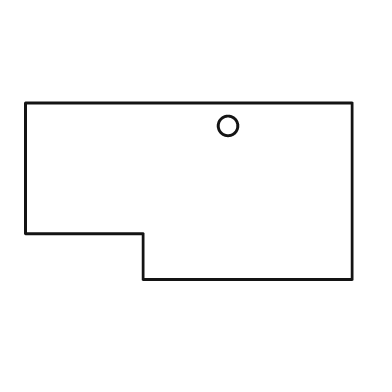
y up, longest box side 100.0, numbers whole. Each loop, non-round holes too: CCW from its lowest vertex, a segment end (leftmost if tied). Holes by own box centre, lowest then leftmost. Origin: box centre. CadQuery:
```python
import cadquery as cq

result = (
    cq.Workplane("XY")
    .moveTo(-14.0, -27.0)
    .lineTo(50.0, -27.0)
    .lineTo(50.0, 27.0)
    .lineTo(-50.0, 27.0)
    .lineTo(-50.0, -13.0)
    .lineTo(-14.0, -13.0)
    .close()
    .moveTo(12.0, 20.0)
    .circle(3.0)
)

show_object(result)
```